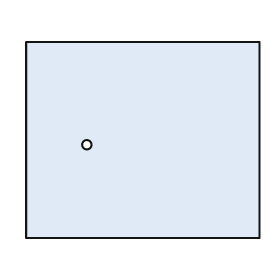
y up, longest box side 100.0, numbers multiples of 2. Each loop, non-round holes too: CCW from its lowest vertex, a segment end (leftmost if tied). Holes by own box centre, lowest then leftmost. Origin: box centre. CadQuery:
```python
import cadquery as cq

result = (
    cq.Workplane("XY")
    .moveTo(-50.0, -42.0)
    .lineTo(50.0, -42.0)
    .lineTo(50.0, 42.0)
    .lineTo(-50.0, 42.0)
    .close()
    .moveTo(-24.0, -2.0)
    .circle(2.0)
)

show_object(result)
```